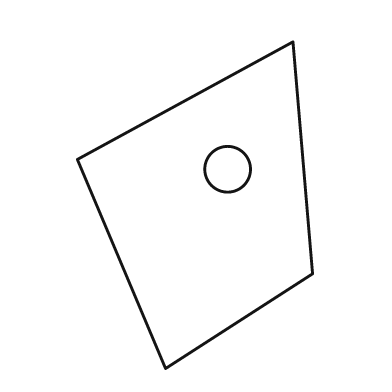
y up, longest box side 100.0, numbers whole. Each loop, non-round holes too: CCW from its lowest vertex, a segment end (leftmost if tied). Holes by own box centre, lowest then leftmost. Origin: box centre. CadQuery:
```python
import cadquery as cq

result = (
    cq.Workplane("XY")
    .moveTo(-9.0, -50.0)
    .lineTo(36.0, -21.0)
    .lineTo(30.0, 50.0)
    .lineTo(-36.0, 14.0)
    .close()
    .moveTo(10.0, 11.0)
    .circle(7.0)
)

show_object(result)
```